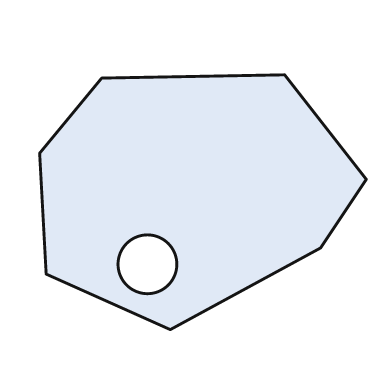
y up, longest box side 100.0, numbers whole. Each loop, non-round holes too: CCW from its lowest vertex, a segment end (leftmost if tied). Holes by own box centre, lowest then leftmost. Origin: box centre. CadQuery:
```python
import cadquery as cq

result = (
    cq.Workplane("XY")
    .moveTo(-10.0, -39.0)
    .lineTo(36.0, -14.0)
    .lineTo(50.0, 7.0)
    .lineTo(25.0, 39.0)
    .lineTo(-31.0, 38.0)
    .lineTo(-50.0, 15.0)
    .lineTo(-48.0, -22.0)
    .close()
    .moveTo(-17.0, -19.0)
    .circle(9.0)
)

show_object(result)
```